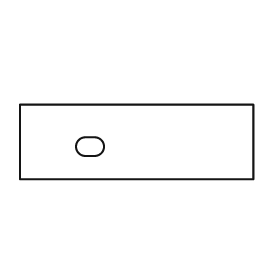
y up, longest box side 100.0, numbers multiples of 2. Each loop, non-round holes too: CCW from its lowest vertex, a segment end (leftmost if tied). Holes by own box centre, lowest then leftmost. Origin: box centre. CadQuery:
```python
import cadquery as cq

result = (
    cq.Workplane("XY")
    .moveTo(-50.0, -16.0)
    .lineTo(50.0, -16.0)
    .lineTo(50.0, 16.0)
    .lineTo(-50.0, 16.0)
    .close()
    .moveTo(-22.0, -6.0)
    .lineTo(-18.0, -6.0)
    .threePointArc((-14.0, -2.0), (-18.0, 2.0))
    .lineTo(-22.0, 2.0)
    .threePointArc((-26.0, -2.0), (-22.0, -6.0))
    .close()
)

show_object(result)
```